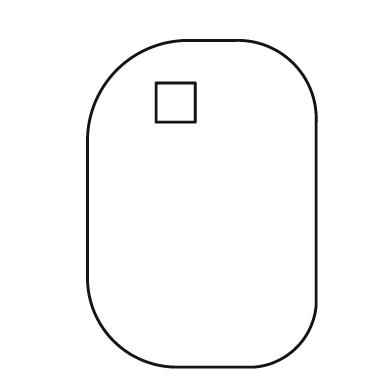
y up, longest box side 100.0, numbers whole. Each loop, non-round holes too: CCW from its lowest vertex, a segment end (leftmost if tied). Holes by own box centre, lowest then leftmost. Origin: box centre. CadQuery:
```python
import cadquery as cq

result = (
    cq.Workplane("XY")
    .moveTo(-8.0, -50.0)
    .lineTo(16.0, -50.0)
    .threePointArc((29.0, -44.0), (35.0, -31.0))
    .lineTo(35.0, 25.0)
    .threePointArc((28.0, 43.0), (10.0, 50.0))
    .lineTo(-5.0, 50.0)
    .threePointArc((-26.0, 41.0), (-35.0, 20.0))
    .lineTo(-35.0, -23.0)
    .threePointArc((-27.0, -42.0), (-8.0, -50.0))
    .close()
    .moveTo(-14.0, 25.0)
    .lineTo(-2.0, 25.0)
    .lineTo(-2.0, 37.0)
    .lineTo(-14.0, 37.0)
    .close()
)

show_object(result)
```